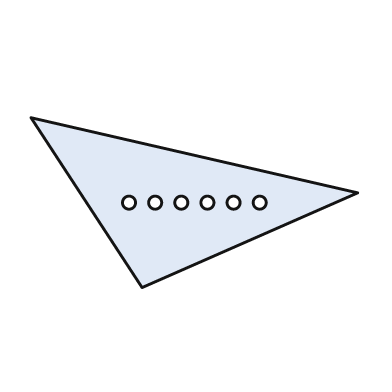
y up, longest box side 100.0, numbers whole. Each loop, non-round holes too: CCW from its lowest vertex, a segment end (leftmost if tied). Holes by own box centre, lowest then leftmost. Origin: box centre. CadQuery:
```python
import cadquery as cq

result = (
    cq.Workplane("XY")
    .moveTo(-16.0, -26.0)
    .lineTo(50.0, 3.0)
    .lineTo(-50.0, 26.0)
    .close()
    .moveTo(-20.0, 0.0)
    .circle(2.0)
    .moveTo(-12.0, 0.0)
    .circle(2.0)
    .moveTo(-4.0, 0.0)
    .circle(2.0)
    .moveTo(4.0, 0.0)
    .circle(2.0)
    .moveTo(12.0, 0.0)
    .circle(2.0)
    .moveTo(20.0, 0.0)
    .circle(2.0)
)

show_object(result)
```